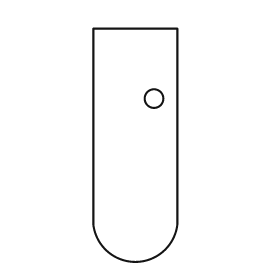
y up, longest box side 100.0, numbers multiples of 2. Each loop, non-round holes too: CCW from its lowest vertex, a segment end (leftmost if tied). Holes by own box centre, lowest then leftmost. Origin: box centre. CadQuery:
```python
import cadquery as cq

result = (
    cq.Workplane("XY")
    .moveTo(-18.0, -34.0)
    .threePointArc((0.0, -50.0), (18.0, -34.0))
    .lineTo(18.0, 50.0)
    .lineTo(-18.0, 50.0)
    .close()
    .moveTo(8.0, 20.0)
    .circle(4.0)
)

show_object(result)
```